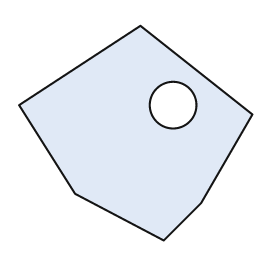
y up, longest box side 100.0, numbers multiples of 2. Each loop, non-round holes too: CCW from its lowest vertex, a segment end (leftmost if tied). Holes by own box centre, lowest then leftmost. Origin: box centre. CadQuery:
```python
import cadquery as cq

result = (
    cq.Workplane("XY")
    .moveTo(12.0, -46.0)
    .lineTo(28.0, -30.0)
    .lineTo(50.0, 8.0)
    .lineTo(2.0, 46.0)
    .lineTo(-50.0, 12.0)
    .lineTo(-26.0, -26.0)
    .close()
    .moveTo(16.0, 12.0)
    .circle(10.0)
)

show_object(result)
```